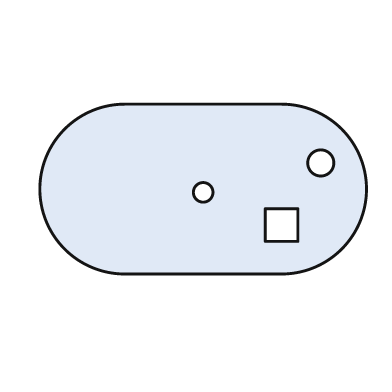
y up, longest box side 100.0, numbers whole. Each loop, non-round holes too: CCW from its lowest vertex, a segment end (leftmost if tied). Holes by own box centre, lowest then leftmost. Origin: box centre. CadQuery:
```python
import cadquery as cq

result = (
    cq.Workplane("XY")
    .moveTo(-24.0, -26.0)
    .lineTo(24.0, -26.0)
    .threePointArc((50.0, 0.0), (24.0, 26.0))
    .lineTo(-24.0, 26.0)
    .threePointArc((-50.0, 0.0), (-24.0, -26.0))
    .close()
    .moveTo(19.0, -16.0)
    .lineTo(29.0, -16.0)
    .lineTo(29.0, -6.0)
    .lineTo(19.0, -6.0)
    .close()
    .moveTo(0.0, -1.0)
    .circle(3.0)
    .moveTo(36.0, 8.0)
    .circle(4.0)
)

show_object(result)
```